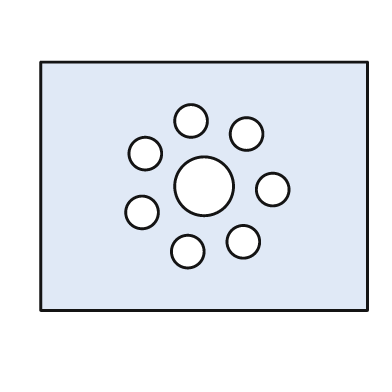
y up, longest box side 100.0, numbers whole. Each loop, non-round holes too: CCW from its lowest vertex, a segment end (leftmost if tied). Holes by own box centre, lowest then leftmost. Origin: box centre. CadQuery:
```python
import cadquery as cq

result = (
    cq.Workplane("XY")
    .moveTo(-50.0, -38.0)
    .lineTo(50.0, -38.0)
    .lineTo(50.0, 38.0)
    .lineTo(-50.0, 38.0)
    .close()
    .moveTo(-5.0, -20.0)
    .circle(5.0)
    .moveTo(12.0, -17.0)
    .circle(5.0)
    .moveTo(-19.0, -8.0)
    .circle(5.0)
    .moveTo(21.0, -1.0)
    .circle(5.0)
    .moveTo(0.0, 0.0)
    .circle(9.0)
    .moveTo(-18.0, 10.0)
    .circle(5.0)
    .moveTo(13.0, 16.0)
    .circle(5.0)
    .moveTo(-4.0, 20.0)
    .circle(5.0)
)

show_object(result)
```